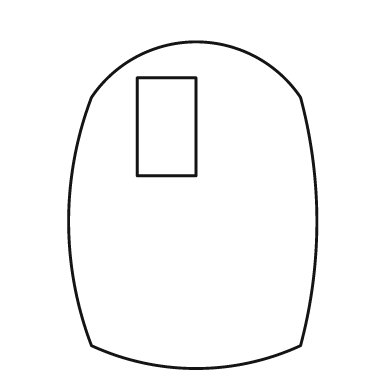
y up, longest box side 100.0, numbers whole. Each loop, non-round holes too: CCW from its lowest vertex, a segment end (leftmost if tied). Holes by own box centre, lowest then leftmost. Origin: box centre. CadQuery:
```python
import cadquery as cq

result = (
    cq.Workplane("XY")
    .moveTo(-31.0, -43.0)
    .threePointArc((1.0, -50.0), (33.0, -43.0))
    .threePointArc((38.0, -5.0), (33.0, 33.0))
    .threePointArc((1.0, 50.0), (-31.0, 33.0))
    .threePointArc((-38.0, -5.0), (-31.0, -43.0))
    .close()
    .moveTo(-17.0, 9.0)
    .lineTo(1.0, 9.0)
    .lineTo(1.0, 39.0)
    .lineTo(-17.0, 39.0)
    .close()
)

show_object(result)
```